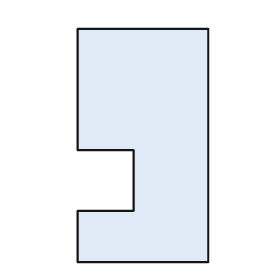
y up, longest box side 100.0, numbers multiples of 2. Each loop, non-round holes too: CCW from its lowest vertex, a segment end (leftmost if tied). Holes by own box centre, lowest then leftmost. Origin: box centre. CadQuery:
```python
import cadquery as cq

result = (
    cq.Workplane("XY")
    .moveTo(-28.0, -50.0)
    .lineTo(28.0, -50.0)
    .lineTo(28.0, 50.0)
    .lineTo(-28.0, 50.0)
    .lineTo(-28.0, -2.0)
    .lineTo(-4.0, -2.0)
    .lineTo(-4.0, -28.0)
    .lineTo(-28.0, -28.0)
    .close()
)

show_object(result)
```